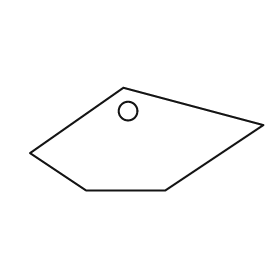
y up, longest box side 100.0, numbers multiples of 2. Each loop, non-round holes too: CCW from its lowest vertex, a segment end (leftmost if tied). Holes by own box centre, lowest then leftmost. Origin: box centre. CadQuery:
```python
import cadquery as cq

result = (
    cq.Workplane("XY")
    .moveTo(-26.0, -22.0)
    .lineTo(8.0, -22.0)
    .lineTo(50.0, 6.0)
    .lineTo(-10.0, 22.0)
    .lineTo(-50.0, -6.0)
    .close()
    .moveTo(-8.0, 12.0)
    .circle(4.0)
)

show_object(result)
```